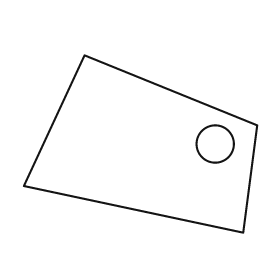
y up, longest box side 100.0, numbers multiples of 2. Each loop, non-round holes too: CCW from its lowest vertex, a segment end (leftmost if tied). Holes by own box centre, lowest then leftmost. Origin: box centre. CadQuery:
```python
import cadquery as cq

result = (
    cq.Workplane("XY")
    .moveTo(44.0, -38.0)
    .lineTo(50.0, 8.0)
    .lineTo(-24.0, 38.0)
    .lineTo(-50.0, -18.0)
    .close()
    .moveTo(32.0, 0.0)
    .circle(8.0)
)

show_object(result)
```